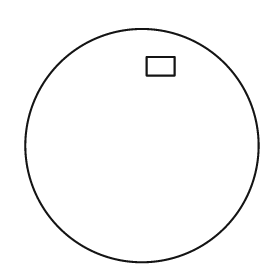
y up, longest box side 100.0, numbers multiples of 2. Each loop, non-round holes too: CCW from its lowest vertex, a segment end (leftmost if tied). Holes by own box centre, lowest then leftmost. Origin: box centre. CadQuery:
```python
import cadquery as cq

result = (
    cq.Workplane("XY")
    .moveTo(0.0, 0.0)
    .circle(50.0)
    .moveTo(2.0, 30.0)
    .lineTo(14.0, 30.0)
    .lineTo(14.0, 38.0)
    .lineTo(2.0, 38.0)
    .close()
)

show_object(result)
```